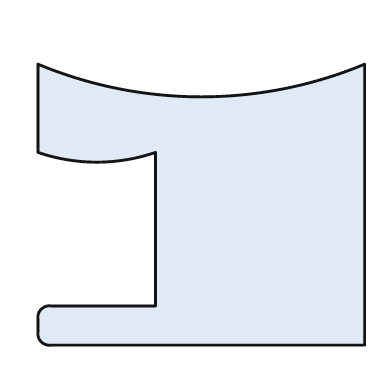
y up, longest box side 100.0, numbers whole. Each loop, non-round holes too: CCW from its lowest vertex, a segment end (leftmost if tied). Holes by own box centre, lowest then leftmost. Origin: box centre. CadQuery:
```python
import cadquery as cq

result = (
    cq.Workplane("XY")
    .moveTo(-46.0, -43.0)
    .lineTo(50.0, -43.0)
    .lineTo(50.0, 43.0)
    .threePointArc((0.0, 33.0), (-50.0, 43.0))
    .lineTo(-50.0, 16.0)
    .threePointArc((-32.0, 13.0), (-14.0, 16.0))
    .lineTo(-14.0, -31.0)
    .lineTo(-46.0, -31.0)
    .threePointArc((-49.0, -32.0), (-50.0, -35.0))
    .lineTo(-50.0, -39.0)
    .threePointArc((-49.0, -42.0), (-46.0, -43.0))
    .close()
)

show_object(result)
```